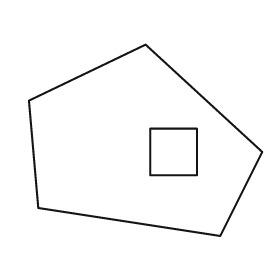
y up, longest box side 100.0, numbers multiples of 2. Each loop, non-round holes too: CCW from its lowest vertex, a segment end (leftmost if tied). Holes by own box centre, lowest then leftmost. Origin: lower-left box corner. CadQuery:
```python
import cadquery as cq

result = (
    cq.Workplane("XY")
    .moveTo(82.0, 0.0)
    .lineTo(100.0, 36.0)
    .lineTo(50.0, 82.0)
    .lineTo(0.0, 58.0)
    .lineTo(4.0, 12.0)
    .close()
    .moveTo(52.0, 26.0)
    .lineTo(72.0, 26.0)
    .lineTo(72.0, 46.0)
    .lineTo(52.0, 46.0)
    .close()
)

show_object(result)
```